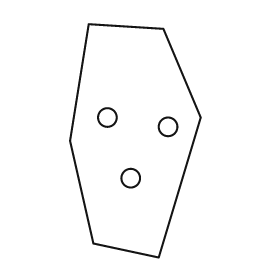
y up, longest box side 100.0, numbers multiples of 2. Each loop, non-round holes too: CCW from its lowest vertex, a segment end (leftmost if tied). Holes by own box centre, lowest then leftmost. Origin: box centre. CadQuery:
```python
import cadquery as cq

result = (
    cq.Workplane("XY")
    .moveTo(10.0, -50.0)
    .lineTo(28.0, 10.0)
    .lineTo(12.0, 48.0)
    .lineTo(-20.0, 50.0)
    .lineTo(-28.0, 0.0)
    .lineTo(-18.0, -44.0)
    .close()
    .moveTo(-2.0, -16.0)
    .circle(4.0)
    .moveTo(14.0, 6.0)
    .circle(4.0)
    .moveTo(-12.0, 10.0)
    .circle(4.0)
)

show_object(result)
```